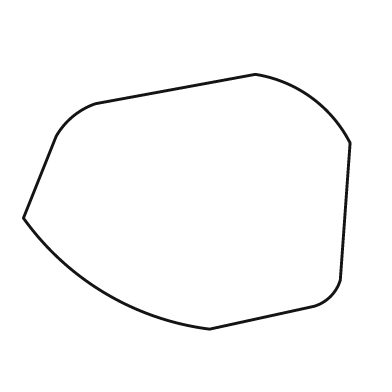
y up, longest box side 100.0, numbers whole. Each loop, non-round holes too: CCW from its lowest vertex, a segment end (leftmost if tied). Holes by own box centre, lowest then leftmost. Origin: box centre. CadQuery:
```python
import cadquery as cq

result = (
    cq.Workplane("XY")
    .moveTo(7.0, -39.0)
    .lineTo(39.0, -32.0)
    .threePointArc((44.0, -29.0), (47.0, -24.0))
    .lineTo(50.0, 18.0)
    .threePointArc((38.0, 32.0), (21.0, 39.0))
    .lineTo(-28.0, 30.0)
    .threePointArc((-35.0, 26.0), (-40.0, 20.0))
    .lineTo(-50.0, -5.0)
    .threePointArc((-25.0, -28.0), (7.0, -39.0))
    .close()
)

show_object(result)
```